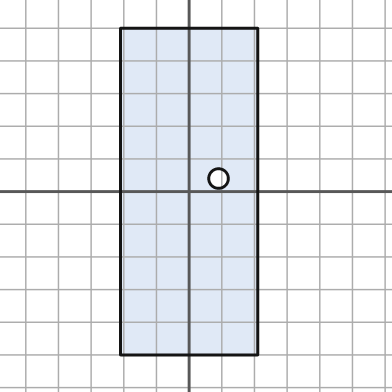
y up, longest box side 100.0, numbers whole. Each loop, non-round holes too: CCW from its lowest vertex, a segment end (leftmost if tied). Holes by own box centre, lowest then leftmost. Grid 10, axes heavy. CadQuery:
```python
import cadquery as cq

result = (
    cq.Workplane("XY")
    .moveTo(-21.0, -50.0)
    .lineTo(21.0, -50.0)
    .lineTo(21.0, 50.0)
    .lineTo(-21.0, 50.0)
    .close()
    .moveTo(9.0, 4.0)
    .circle(3.0)
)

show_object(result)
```